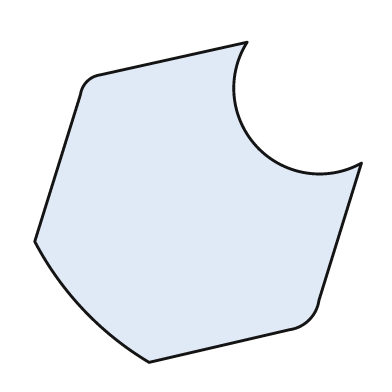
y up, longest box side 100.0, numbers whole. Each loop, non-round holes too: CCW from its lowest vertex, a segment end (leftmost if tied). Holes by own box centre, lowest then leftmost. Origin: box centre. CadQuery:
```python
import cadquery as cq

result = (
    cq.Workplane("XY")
    .moveTo(-15.0, -49.0)
    .lineTo(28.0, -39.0)
    .threePointArc((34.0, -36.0), (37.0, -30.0))
    .lineTo(50.0, 12.0)
    .threePointArc((18.0, 17.0), (15.0, 49.0))
    .lineTo(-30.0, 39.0)
    .threePointArc((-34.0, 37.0), (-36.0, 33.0))
    .lineTo(-50.0, -12.0)
    .threePointArc((-35.0, -33.0), (-15.0, -49.0))
    .close()
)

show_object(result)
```